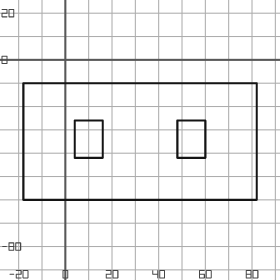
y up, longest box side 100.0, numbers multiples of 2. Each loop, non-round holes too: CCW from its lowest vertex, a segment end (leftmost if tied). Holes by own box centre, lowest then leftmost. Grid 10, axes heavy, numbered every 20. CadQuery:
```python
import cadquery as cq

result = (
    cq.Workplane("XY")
    .moveTo(-18.0, -60.0)
    .lineTo(82.0, -60.0)
    .lineTo(82.0, -10.0)
    .lineTo(-18.0, -10.0)
    .close()
    .moveTo(4.0, -42.0)
    .lineTo(16.0, -42.0)
    .lineTo(16.0, -26.0)
    .lineTo(4.0, -26.0)
    .close()
    .moveTo(48.0, -42.0)
    .lineTo(60.0, -42.0)
    .lineTo(60.0, -26.0)
    .lineTo(48.0, -26.0)
    .close()
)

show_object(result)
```